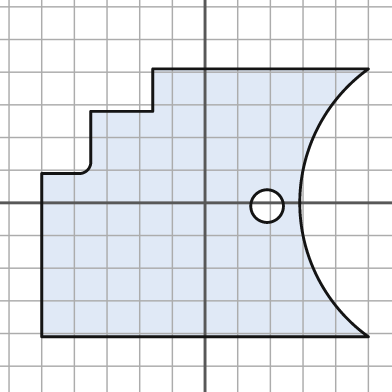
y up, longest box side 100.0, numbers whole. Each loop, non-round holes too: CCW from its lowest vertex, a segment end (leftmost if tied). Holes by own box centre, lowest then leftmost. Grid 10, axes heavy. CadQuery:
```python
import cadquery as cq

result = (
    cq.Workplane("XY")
    .moveTo(-50.0, -41.0)
    .lineTo(50.0, -41.0)
    .threePointArc((29.0, 0.0), (50.0, 41.0))
    .lineTo(-16.0, 41.0)
    .lineTo(-16.0, 28.0)
    .lineTo(-35.0, 28.0)
    .lineTo(-35.0, 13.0)
    .threePointArc((-36.0, 10.0), (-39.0, 9.0))
    .lineTo(-50.0, 9.0)
    .close()
    .moveTo(19.0, -1.0)
    .circle(5.0)
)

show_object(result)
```